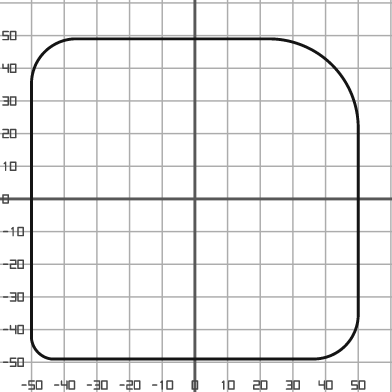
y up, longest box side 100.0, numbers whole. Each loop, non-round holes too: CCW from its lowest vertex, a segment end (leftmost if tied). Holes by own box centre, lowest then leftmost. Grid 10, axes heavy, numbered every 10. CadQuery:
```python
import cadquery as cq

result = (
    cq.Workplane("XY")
    .moveTo(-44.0, -49.0)
    .lineTo(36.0, -49.0)
    .threePointArc((46.0, -45.0), (50.0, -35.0))
    .lineTo(50.0, 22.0)
    .threePointArc((42.0, 41.0), (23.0, 49.0))
    .lineTo(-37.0, 49.0)
    .threePointArc((-46.0, 45.0), (-50.0, 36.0))
    .lineTo(-50.0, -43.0)
    .threePointArc((-48.0, -47.0), (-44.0, -49.0))
    .close()
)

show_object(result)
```